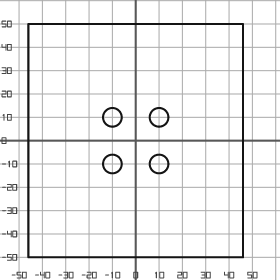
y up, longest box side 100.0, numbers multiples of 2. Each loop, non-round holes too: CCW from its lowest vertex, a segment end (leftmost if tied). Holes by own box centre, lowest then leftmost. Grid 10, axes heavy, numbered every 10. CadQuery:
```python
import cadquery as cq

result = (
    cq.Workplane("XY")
    .moveTo(-46.0, -50.0)
    .lineTo(46.0, -50.0)
    .lineTo(46.0, 50.0)
    .lineTo(-46.0, 50.0)
    .close()
    .moveTo(-10.0, -10.0)
    .circle(4.0)
    .moveTo(10.0, -10.0)
    .circle(4.0)
    .moveTo(-10.0, 10.0)
    .circle(4.0)
    .moveTo(10.0, 10.0)
    .circle(4.0)
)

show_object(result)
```